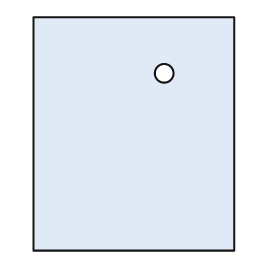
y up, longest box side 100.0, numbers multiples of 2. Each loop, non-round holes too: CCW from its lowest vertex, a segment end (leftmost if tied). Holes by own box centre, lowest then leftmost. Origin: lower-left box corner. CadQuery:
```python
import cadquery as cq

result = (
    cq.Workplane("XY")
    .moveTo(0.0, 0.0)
    .lineTo(86.0, 0.0)
    .lineTo(86.0, 100.0)
    .lineTo(0.0, 100.0)
    .close()
    .moveTo(56.0, 76.0)
    .circle(4.0)
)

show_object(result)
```